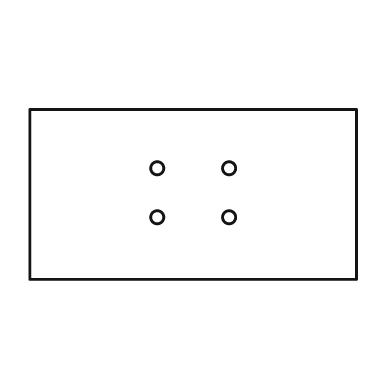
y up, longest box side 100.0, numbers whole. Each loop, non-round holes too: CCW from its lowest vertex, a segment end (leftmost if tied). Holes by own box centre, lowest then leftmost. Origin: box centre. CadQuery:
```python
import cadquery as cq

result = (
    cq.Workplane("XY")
    .moveTo(-50.0, -26.0)
    .lineTo(50.0, -26.0)
    .lineTo(50.0, 26.0)
    .lineTo(-50.0, 26.0)
    .close()
    .moveTo(-11.0, -7.0)
    .circle(2.0)
    .moveTo(11.0, -7.0)
    .circle(2.0)
    .moveTo(-11.0, 8.0)
    .circle(2.0)
    .moveTo(11.0, 8.0)
    .circle(2.0)
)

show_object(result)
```